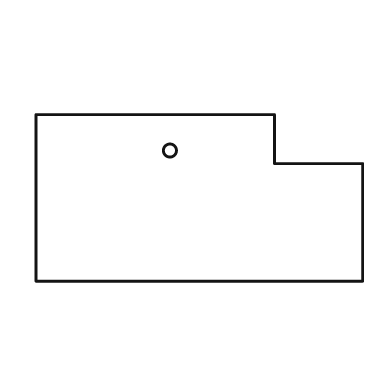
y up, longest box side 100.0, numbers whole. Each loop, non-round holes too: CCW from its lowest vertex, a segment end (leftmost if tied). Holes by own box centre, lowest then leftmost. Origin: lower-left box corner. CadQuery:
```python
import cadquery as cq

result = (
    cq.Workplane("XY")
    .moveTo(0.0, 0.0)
    .lineTo(100.0, 0.0)
    .lineTo(100.0, 36.0)
    .lineTo(73.0, 36.0)
    .lineTo(73.0, 51.0)
    .lineTo(0.0, 51.0)
    .close()
    .moveTo(41.0, 40.0)
    .circle(2.0)
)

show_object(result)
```